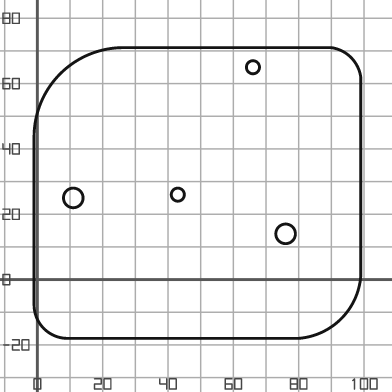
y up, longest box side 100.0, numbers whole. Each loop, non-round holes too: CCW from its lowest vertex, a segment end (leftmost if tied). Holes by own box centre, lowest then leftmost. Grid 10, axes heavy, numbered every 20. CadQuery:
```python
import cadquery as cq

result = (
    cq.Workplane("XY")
    .moveTo(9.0, -18.0)
    .lineTo(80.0, -18.0)
    .threePointArc((93.0, -12.0), (99.0, 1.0))
    .lineTo(99.0, 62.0)
    .threePointArc((96.0, 68.0), (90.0, 71.0))
    .lineTo(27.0, 71.0)
    .threePointArc((7.0, 63.0), (-1.0, 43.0))
    .lineTo(-1.0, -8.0)
    .threePointArc((2.0, -15.0), (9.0, -18.0))
    .close()
    .moveTo(76.0, 14.0)
    .circle(3.0)
    .moveTo(11.0, 25.0)
    .circle(3.0)
    .moveTo(43.0, 26.0)
    .circle(2.0)
    .moveTo(66.0, 65.0)
    .circle(2.0)
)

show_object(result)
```